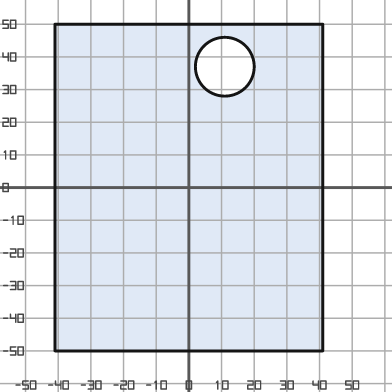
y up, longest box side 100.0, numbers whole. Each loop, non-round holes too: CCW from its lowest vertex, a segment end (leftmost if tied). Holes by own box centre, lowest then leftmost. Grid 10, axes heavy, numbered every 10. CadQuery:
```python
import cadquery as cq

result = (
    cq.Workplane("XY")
    .moveTo(-41.0, -50.0)
    .lineTo(41.0, -50.0)
    .lineTo(41.0, 50.0)
    .lineTo(-41.0, 50.0)
    .close()
    .moveTo(11.0, 37.0)
    .circle(9.0)
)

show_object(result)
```